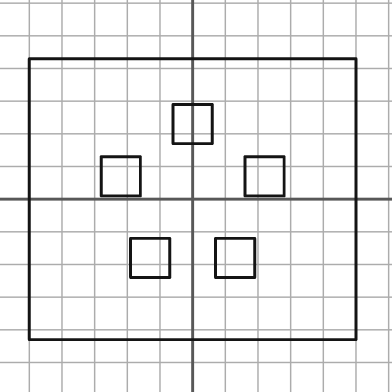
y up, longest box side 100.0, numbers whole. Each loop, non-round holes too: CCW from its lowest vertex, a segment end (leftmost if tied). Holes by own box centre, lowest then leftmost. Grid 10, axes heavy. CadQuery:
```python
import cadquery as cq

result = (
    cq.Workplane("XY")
    .moveTo(-50.0, -43.0)
    .lineTo(50.0, -43.0)
    .lineTo(50.0, 43.0)
    .lineTo(-50.0, 43.0)
    .close()
    .moveTo(-19.0, -24.0)
    .lineTo(-7.0, -24.0)
    .lineTo(-7.0, -12.0)
    .lineTo(-19.0, -12.0)
    .close()
    .moveTo(7.0, -24.0)
    .lineTo(19.0, -24.0)
    .lineTo(19.0, -12.0)
    .lineTo(7.0, -12.0)
    .close()
    .moveTo(-28.0, 1.0)
    .lineTo(-16.0, 1.0)
    .lineTo(-16.0, 13.0)
    .lineTo(-28.0, 13.0)
    .close()
    .moveTo(16.0, 1.0)
    .lineTo(28.0, 1.0)
    .lineTo(28.0, 13.0)
    .lineTo(16.0, 13.0)
    .close()
    .moveTo(-6.0, 17.0)
    .lineTo(6.0, 17.0)
    .lineTo(6.0, 29.0)
    .lineTo(-6.0, 29.0)
    .close()
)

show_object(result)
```